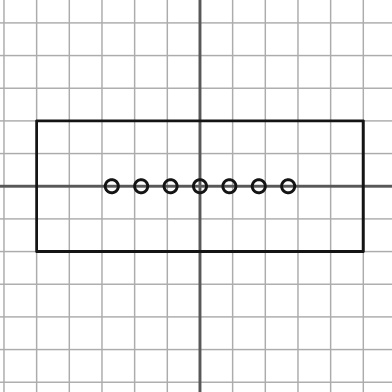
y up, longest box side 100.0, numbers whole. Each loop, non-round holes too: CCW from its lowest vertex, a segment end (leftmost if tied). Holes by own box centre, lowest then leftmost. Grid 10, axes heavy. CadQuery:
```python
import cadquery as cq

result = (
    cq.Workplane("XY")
    .moveTo(-50.0, -20.0)
    .lineTo(50.0, -20.0)
    .lineTo(50.0, 20.0)
    .lineTo(-50.0, 20.0)
    .close()
    .moveTo(-27.0, 0.0)
    .circle(2.0)
    .moveTo(-18.0, 0.0)
    .circle(2.0)
    .moveTo(-9.0, 0.0)
    .circle(2.0)
    .moveTo(0.0, 0.0)
    .circle(2.0)
    .moveTo(9.0, 0.0)
    .circle(2.0)
    .moveTo(18.0, 0.0)
    .circle(2.0)
    .moveTo(27.0, 0.0)
    .circle(2.0)
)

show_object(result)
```